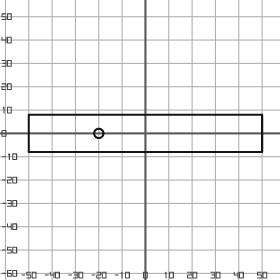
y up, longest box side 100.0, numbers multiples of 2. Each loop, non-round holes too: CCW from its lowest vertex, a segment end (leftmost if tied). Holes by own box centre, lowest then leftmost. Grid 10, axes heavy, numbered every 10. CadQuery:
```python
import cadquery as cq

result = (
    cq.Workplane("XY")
    .moveTo(-50.0, -8.0)
    .lineTo(50.0, -8.0)
    .lineTo(50.0, 8.0)
    .lineTo(-50.0, 8.0)
    .close()
    .moveTo(-20.0, 0.0)
    .circle(2.0)
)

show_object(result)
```